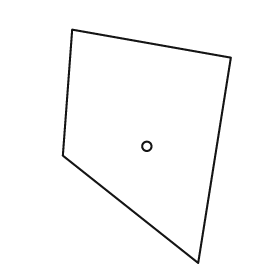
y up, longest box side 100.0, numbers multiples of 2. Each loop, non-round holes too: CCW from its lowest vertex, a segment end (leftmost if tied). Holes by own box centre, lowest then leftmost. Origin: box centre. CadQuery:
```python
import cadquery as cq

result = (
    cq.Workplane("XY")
    .moveTo(22.0, -50.0)
    .lineTo(36.0, 38.0)
    .lineTo(-32.0, 50.0)
    .lineTo(-36.0, -4.0)
    .close()
    .moveTo(0.0, 0.0)
    .circle(2.0)
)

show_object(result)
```